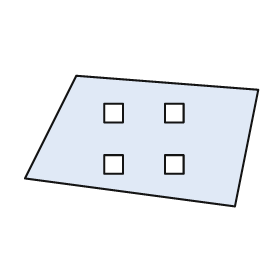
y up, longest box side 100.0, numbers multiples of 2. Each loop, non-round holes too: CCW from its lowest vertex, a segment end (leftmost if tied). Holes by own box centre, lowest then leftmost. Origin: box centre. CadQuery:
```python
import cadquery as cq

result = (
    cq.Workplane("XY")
    .moveTo(40.0, -28.0)
    .lineTo(50.0, 22.0)
    .lineTo(-28.0, 28.0)
    .lineTo(-50.0, -16.0)
    .close()
    .moveTo(-16.0, -14.0)
    .lineTo(-8.0, -14.0)
    .lineTo(-8.0, -6.0)
    .lineTo(-16.0, -6.0)
    .close()
    .moveTo(10.0, -14.0)
    .lineTo(18.0, -14.0)
    .lineTo(18.0, -6.0)
    .lineTo(10.0, -6.0)
    .close()
    .moveTo(-16.0, 8.0)
    .lineTo(-8.0, 8.0)
    .lineTo(-8.0, 16.0)
    .lineTo(-16.0, 16.0)
    .close()
    .moveTo(10.0, 8.0)
    .lineTo(18.0, 8.0)
    .lineTo(18.0, 16.0)
    .lineTo(10.0, 16.0)
    .close()
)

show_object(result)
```